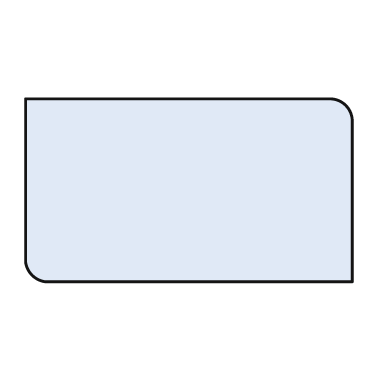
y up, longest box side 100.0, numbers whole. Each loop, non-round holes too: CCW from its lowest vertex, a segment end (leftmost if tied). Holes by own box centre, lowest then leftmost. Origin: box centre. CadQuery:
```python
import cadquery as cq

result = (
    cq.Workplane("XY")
    .moveTo(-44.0, -28.0)
    .lineTo(50.0, -28.0)
    .lineTo(50.0, 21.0)
    .threePointArc((48.0, 26.0), (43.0, 28.0))
    .lineTo(-50.0, 28.0)
    .lineTo(-50.0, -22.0)
    .threePointArc((-48.0, -26.0), (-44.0, -28.0))
    .close()
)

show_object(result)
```